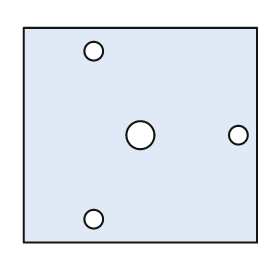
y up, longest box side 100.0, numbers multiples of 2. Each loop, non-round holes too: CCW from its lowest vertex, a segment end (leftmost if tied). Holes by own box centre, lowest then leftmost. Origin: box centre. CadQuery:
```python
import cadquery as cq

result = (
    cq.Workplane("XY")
    .moveTo(-50.0, -46.0)
    .lineTo(50.0, -46.0)
    .lineTo(50.0, 46.0)
    .lineTo(-50.0, 46.0)
    .close()
    .moveTo(-20.0, -36.0)
    .circle(4.0)
    .moveTo(0.0, 0.0)
    .circle(6.0)
    .moveTo(42.0, 0.0)
    .circle(4.0)
    .moveTo(-20.0, 36.0)
    .circle(4.0)
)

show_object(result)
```